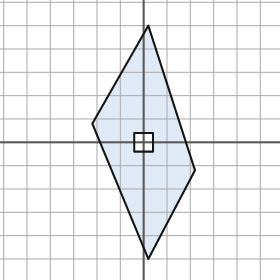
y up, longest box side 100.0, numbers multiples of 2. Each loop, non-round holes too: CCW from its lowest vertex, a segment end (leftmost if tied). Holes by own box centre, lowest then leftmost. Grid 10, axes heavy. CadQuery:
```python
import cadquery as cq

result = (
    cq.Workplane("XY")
    .moveTo(2.0, -50.0)
    .lineTo(22.0, -12.0)
    .lineTo(2.0, 50.0)
    .lineTo(-22.0, 8.0)
    .close()
    .moveTo(-4.0, -4.0)
    .lineTo(4.0, -4.0)
    .lineTo(4.0, 4.0)
    .lineTo(-4.0, 4.0)
    .close()
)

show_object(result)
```